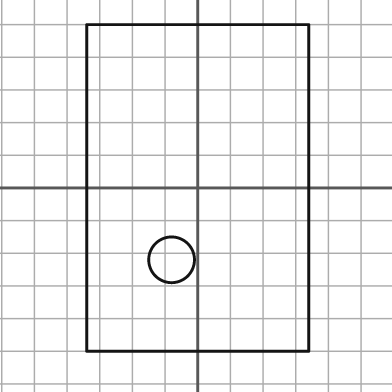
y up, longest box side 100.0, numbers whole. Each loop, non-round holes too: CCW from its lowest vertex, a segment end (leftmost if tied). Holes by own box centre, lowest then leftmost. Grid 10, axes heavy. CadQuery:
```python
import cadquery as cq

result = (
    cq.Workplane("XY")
    .moveTo(-34.0, -50.0)
    .lineTo(34.0, -50.0)
    .lineTo(34.0, 50.0)
    .lineTo(-34.0, 50.0)
    .close()
    .moveTo(-8.0, -22.0)
    .circle(7.0)
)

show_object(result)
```